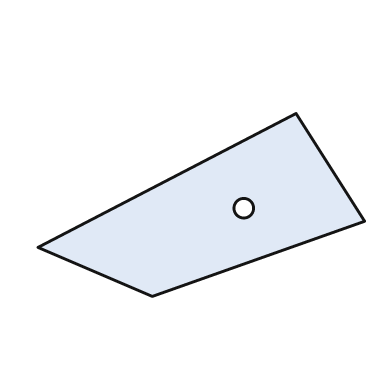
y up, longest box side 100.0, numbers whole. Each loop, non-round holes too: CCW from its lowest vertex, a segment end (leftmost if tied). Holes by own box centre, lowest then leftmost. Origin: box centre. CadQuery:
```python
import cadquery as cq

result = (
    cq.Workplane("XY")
    .moveTo(-15.0, -28.0)
    .lineTo(50.0, -5.0)
    .lineTo(29.0, 28.0)
    .lineTo(-50.0, -13.0)
    .close()
    .moveTo(13.0, -1.0)
    .circle(3.0)
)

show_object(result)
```